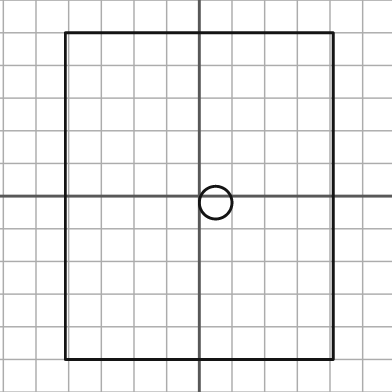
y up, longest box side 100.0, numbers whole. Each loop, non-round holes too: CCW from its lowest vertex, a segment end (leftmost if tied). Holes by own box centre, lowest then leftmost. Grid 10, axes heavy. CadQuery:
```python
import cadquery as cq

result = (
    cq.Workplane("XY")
    .moveTo(-41.0, -50.0)
    .lineTo(41.0, -50.0)
    .lineTo(41.0, 50.0)
    .lineTo(-41.0, 50.0)
    .close()
    .moveTo(5.0, -2.0)
    .circle(5.0)
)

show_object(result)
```